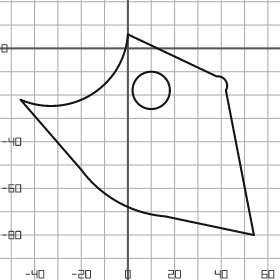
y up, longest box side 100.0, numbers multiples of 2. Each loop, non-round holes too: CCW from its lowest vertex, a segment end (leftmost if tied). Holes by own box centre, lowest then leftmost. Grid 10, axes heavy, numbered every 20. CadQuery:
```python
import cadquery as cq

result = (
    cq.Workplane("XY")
    .moveTo(54.0, -80.0)
    .lineTo(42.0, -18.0)
    .threePointArc((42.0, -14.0), (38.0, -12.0))
    .lineTo(0.0, 6.0)
    .threePointArc((-16.0, -20.0), (-46.0, -22.0))
    .lineTo(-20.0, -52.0)
    .threePointArc((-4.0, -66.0), (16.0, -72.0))
    .close()
    .moveTo(10.0, -18.0)
    .circle(8.0)
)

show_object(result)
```